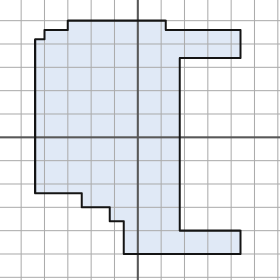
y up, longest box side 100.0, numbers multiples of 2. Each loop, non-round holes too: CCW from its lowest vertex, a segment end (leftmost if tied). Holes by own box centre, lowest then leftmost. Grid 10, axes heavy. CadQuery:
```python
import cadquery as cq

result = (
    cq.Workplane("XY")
    .moveTo(-6.0, -50.0)
    .lineTo(44.0, -50.0)
    .lineTo(44.0, -40.0)
    .lineTo(18.0, -40.0)
    .lineTo(18.0, 34.0)
    .lineTo(44.0, 34.0)
    .lineTo(44.0, 46.0)
    .lineTo(12.0, 46.0)
    .lineTo(12.0, 50.0)
    .lineTo(-30.0, 50.0)
    .lineTo(-30.0, 46.0)
    .lineTo(-40.0, 46.0)
    .lineTo(-40.0, 42.0)
    .lineTo(-44.0, 42.0)
    .lineTo(-44.0, -24.0)
    .lineTo(-24.0, -24.0)
    .lineTo(-24.0, -30.0)
    .lineTo(-12.0, -30.0)
    .lineTo(-12.0, -36.0)
    .lineTo(-6.0, -36.0)
    .close()
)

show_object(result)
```